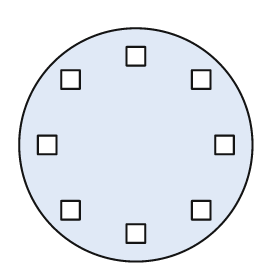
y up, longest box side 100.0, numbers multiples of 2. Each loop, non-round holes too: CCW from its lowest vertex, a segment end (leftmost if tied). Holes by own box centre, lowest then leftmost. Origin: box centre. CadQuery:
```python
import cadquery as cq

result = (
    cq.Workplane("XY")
    .moveTo(0.0, 0.0)
    .circle(50.0)
    .moveTo(-4.0, -42.0)
    .lineTo(4.0, -42.0)
    .lineTo(4.0, -34.0)
    .lineTo(-4.0, -34.0)
    .close()
    .moveTo(-32.0, -32.0)
    .lineTo(-24.0, -32.0)
    .lineTo(-24.0, -24.0)
    .lineTo(-32.0, -24.0)
    .close()
    .moveTo(24.0, -32.0)
    .lineTo(32.0, -32.0)
    .lineTo(32.0, -24.0)
    .lineTo(24.0, -24.0)
    .close()
    .moveTo(-42.0, -4.0)
    .lineTo(-34.0, -4.0)
    .lineTo(-34.0, 4.0)
    .lineTo(-42.0, 4.0)
    .close()
    .moveTo(34.0, -4.0)
    .lineTo(42.0, -4.0)
    .lineTo(42.0, 4.0)
    .lineTo(34.0, 4.0)
    .close()
    .moveTo(-32.0, 24.0)
    .lineTo(-24.0, 24.0)
    .lineTo(-24.0, 32.0)
    .lineTo(-32.0, 32.0)
    .close()
    .moveTo(24.0, 24.0)
    .lineTo(32.0, 24.0)
    .lineTo(32.0, 32.0)
    .lineTo(24.0, 32.0)
    .close()
    .moveTo(-4.0, 34.0)
    .lineTo(4.0, 34.0)
    .lineTo(4.0, 42.0)
    .lineTo(-4.0, 42.0)
    .close()
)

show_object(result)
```